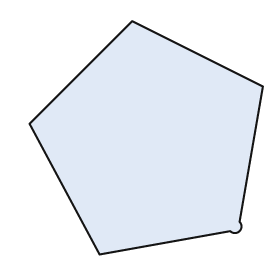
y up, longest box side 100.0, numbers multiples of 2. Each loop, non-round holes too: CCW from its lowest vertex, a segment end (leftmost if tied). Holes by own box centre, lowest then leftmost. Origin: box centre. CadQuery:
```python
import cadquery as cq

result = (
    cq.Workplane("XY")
    .moveTo(-20.0, -50.0)
    .lineTo(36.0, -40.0)
    .threePointArc((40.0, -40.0), (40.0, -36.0))
    .lineTo(50.0, 22.0)
    .lineTo(-6.0, 50.0)
    .lineTo(-50.0, 6.0)
    .close()
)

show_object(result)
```